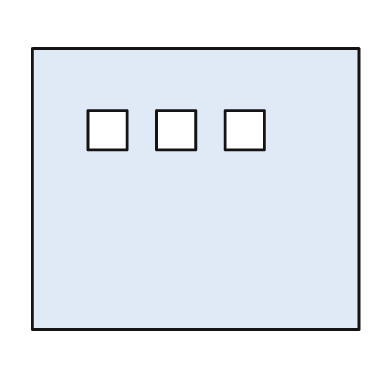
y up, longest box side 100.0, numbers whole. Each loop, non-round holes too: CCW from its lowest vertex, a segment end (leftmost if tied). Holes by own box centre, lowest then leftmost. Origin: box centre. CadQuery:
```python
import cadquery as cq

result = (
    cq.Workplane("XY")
    .moveTo(-50.0, -43.0)
    .lineTo(50.0, -43.0)
    .lineTo(50.0, 43.0)
    .lineTo(-50.0, 43.0)
    .close()
    .moveTo(-33.0, 12.0)
    .lineTo(-21.0, 12.0)
    .lineTo(-21.0, 24.0)
    .lineTo(-33.0, 24.0)
    .close()
    .moveTo(-12.0, 12.0)
    .lineTo(0.0, 12.0)
    .lineTo(0.0, 24.0)
    .lineTo(-12.0, 24.0)
    .close()
    .moveTo(9.0, 12.0)
    .lineTo(21.0, 12.0)
    .lineTo(21.0, 24.0)
    .lineTo(9.0, 24.0)
    .close()
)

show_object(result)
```